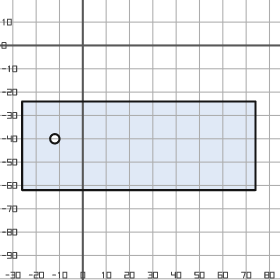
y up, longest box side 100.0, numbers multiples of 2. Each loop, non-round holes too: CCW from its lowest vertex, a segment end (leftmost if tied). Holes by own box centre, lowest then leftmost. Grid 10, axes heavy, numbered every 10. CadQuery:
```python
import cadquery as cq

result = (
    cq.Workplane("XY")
    .moveTo(-26.0, -62.0)
    .lineTo(74.0, -62.0)
    .lineTo(74.0, -24.0)
    .lineTo(-26.0, -24.0)
    .close()
    .moveTo(-12.0, -40.0)
    .circle(2.0)
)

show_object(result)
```